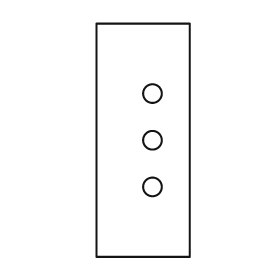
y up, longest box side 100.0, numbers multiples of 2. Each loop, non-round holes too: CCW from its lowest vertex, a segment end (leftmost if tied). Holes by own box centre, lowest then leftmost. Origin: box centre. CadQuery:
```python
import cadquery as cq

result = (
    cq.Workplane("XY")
    .moveTo(-20.0, -50.0)
    .lineTo(20.0, -50.0)
    .lineTo(20.0, 50.0)
    .lineTo(-20.0, 50.0)
    .close()
    .moveTo(4.0, -20.0)
    .circle(4.0)
    .moveTo(4.0, 0.0)
    .circle(4.0)
    .moveTo(4.0, 20.0)
    .circle(4.0)
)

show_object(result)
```